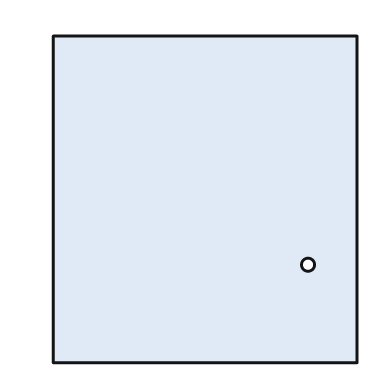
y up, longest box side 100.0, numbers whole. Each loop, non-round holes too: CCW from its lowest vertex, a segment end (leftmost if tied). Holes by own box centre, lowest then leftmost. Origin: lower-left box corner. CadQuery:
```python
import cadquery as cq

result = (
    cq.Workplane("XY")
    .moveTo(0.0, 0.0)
    .lineTo(93.0, 0.0)
    .lineTo(93.0, 100.0)
    .lineTo(0.0, 100.0)
    .close()
    .moveTo(78.0, 30.0)
    .circle(2.0)
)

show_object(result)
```